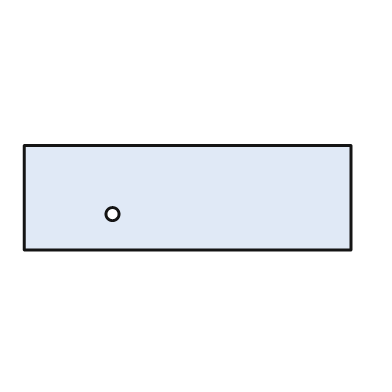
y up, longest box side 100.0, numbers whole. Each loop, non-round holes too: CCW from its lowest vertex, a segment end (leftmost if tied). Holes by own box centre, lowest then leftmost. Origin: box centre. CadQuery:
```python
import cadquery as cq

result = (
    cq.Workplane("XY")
    .moveTo(-50.0, -16.0)
    .lineTo(50.0, -16.0)
    .lineTo(50.0, 16.0)
    .lineTo(-50.0, 16.0)
    .close()
    .moveTo(-23.0, -5.0)
    .circle(2.0)
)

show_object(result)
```